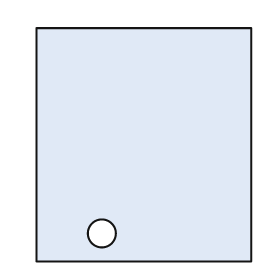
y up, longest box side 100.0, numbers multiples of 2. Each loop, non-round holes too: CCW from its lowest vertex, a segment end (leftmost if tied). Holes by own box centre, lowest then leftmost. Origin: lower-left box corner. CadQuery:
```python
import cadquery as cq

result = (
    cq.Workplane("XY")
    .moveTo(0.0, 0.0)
    .lineTo(92.0, 0.0)
    .lineTo(92.0, 100.0)
    .lineTo(0.0, 100.0)
    .close()
    .moveTo(28.0, 12.0)
    .circle(6.0)
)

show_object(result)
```